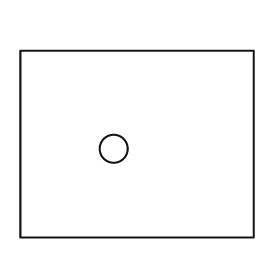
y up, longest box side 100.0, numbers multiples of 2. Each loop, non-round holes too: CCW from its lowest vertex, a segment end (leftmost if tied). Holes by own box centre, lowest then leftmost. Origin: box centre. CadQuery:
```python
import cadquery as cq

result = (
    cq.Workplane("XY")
    .moveTo(-50.0, -40.0)
    .lineTo(50.0, -40.0)
    .lineTo(50.0, 40.0)
    .lineTo(-50.0, 40.0)
    .close()
    .moveTo(-10.0, -2.0)
    .circle(6.0)
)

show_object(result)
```